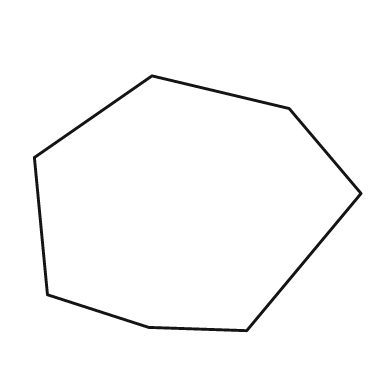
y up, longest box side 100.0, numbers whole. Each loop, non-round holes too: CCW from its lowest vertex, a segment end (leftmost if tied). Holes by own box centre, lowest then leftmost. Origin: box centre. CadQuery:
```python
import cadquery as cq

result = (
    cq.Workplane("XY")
    .moveTo(15.0, -39.0)
    .lineTo(50.0, 3.0)
    .lineTo(28.0, 29.0)
    .lineTo(-14.0, 39.0)
    .lineTo(-50.0, 14.0)
    .lineTo(-46.0, -28.0)
    .lineTo(-15.0, -38.0)
    .close()
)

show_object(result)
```